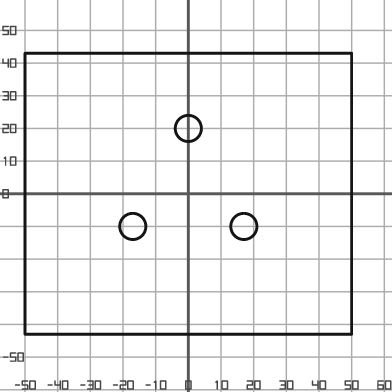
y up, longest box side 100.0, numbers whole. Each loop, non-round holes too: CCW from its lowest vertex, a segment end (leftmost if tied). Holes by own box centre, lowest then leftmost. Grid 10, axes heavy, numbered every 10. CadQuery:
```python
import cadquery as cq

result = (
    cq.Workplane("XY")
    .moveTo(-50.0, -43.0)
    .lineTo(50.0, -43.0)
    .lineTo(50.0, 43.0)
    .lineTo(-50.0, 43.0)
    .close()
    .moveTo(-17.0, -10.0)
    .circle(4.0)
    .moveTo(17.0, -10.0)
    .circle(4.0)
    .moveTo(0.0, 20.0)
    .circle(4.0)
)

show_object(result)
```